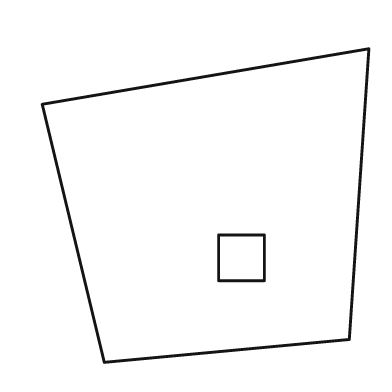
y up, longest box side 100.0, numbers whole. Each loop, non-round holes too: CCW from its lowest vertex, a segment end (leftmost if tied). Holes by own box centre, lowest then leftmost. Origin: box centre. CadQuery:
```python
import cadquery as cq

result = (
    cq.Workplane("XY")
    .moveTo(-31.0, -48.0)
    .lineTo(44.0, -41.0)
    .lineTo(50.0, 48.0)
    .lineTo(-50.0, 31.0)
    .close()
    .moveTo(4.0, -23.0)
    .lineTo(18.0, -23.0)
    .lineTo(18.0, -9.0)
    .lineTo(4.0, -9.0)
    .close()
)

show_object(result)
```